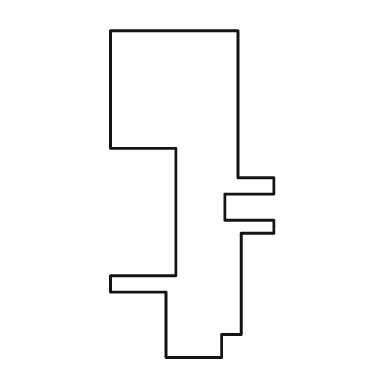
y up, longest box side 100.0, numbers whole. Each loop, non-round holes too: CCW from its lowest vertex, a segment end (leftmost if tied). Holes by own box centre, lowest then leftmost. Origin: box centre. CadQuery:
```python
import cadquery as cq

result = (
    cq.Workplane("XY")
    .moveTo(-8.0, -50.0)
    .lineTo(9.0, -50.0)
    .lineTo(9.0, -43.0)
    .lineTo(15.0, -43.0)
    .lineTo(15.0, -12.0)
    .lineTo(25.0, -12.0)
    .lineTo(25.0, -8.0)
    .lineTo(10.0, -8.0)
    .lineTo(10.0, 0.0)
    .lineTo(25.0, 0.0)
    .lineTo(25.0, 5.0)
    .lineTo(14.0, 5.0)
    .lineTo(14.0, 50.0)
    .lineTo(-25.0, 50.0)
    .lineTo(-25.0, 14.0)
    .lineTo(-5.0, 14.0)
    .lineTo(-5.0, -25.0)
    .lineTo(-25.0, -25.0)
    .lineTo(-25.0, -30.0)
    .lineTo(-8.0, -30.0)
    .close()
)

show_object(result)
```